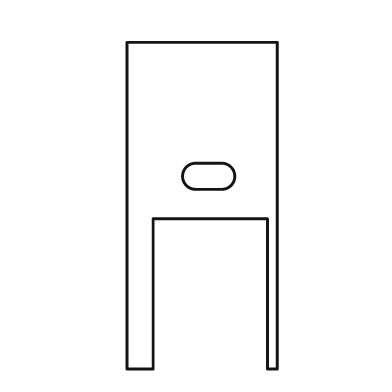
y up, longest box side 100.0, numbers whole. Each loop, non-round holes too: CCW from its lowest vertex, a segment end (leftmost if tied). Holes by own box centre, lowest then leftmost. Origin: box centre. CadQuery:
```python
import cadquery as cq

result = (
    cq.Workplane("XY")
    .moveTo(-23.0, -50.0)
    .lineTo(-15.0, -50.0)
    .lineTo(-15.0, -4.0)
    .lineTo(20.0, -4.0)
    .lineTo(20.0, -50.0)
    .lineTo(23.0, -50.0)
    .lineTo(23.0, 50.0)
    .lineTo(-23.0, 50.0)
    .close()
    .moveTo(-2.0, 5.0)
    .lineTo(6.0, 5.0)
    .threePointArc((10.0, 9.0), (6.0, 13.0))
    .lineTo(-2.0, 13.0)
    .threePointArc((-6.0, 9.0), (-2.0, 5.0))
    .close()
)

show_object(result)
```